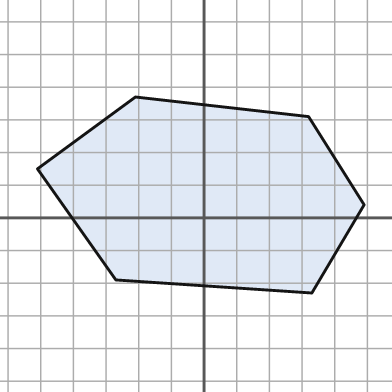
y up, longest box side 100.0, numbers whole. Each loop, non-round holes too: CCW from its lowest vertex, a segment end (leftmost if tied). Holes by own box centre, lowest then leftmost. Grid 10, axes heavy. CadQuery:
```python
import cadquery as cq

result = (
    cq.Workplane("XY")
    .moveTo(33.0, -23.0)
    .lineTo(49.0, 4.0)
    .lineTo(32.0, 31.0)
    .lineTo(-21.0, 37.0)
    .lineTo(-51.0, 15.0)
    .lineTo(-27.0, -19.0)
    .close()
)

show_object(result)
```